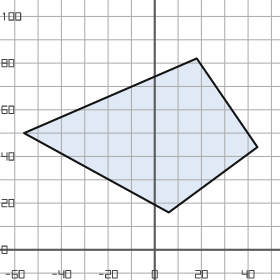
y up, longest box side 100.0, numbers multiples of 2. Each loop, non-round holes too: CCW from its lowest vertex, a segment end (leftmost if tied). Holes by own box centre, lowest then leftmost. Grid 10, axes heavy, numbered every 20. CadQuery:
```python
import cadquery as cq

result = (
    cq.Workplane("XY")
    .moveTo(6.0, 16.0)
    .lineTo(44.0, 44.0)
    .lineTo(18.0, 82.0)
    .lineTo(-56.0, 50.0)
    .close()
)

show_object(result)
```